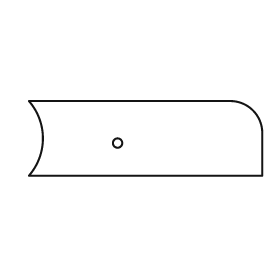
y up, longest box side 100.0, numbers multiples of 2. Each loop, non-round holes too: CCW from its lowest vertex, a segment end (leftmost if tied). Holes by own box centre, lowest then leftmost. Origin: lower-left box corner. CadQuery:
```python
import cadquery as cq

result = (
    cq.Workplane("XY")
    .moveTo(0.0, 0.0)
    .lineTo(100.0, 0.0)
    .lineTo(100.0, 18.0)
    .threePointArc((96.0, 28.0), (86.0, 32.0))
    .lineTo(0.0, 32.0)
    .threePointArc((6.0, 16.0), (0.0, 0.0))
    .close()
    .moveTo(38.0, 14.0)
    .circle(2.0)
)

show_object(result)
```